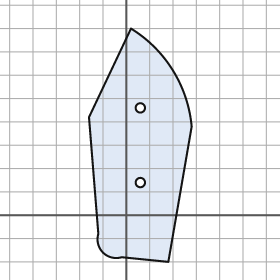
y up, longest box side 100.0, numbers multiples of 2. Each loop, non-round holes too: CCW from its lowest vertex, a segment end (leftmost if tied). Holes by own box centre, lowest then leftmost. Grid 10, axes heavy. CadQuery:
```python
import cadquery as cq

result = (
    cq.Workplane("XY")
    .moveTo(18.0, -20.0)
    .lineTo(28.0, 38.0)
    .threePointArc((20.0, 62.0), (2.0, 80.0))
    .lineTo(-16.0, 42.0)
    .lineTo(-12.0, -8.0)
    .threePointArc((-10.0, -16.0), (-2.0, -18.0))
    .close()
    .moveTo(6.0, 14.0)
    .circle(2.0)
    .moveTo(6.0, 46.0)
    .circle(2.0)
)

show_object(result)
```